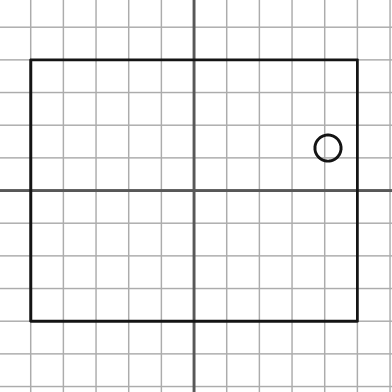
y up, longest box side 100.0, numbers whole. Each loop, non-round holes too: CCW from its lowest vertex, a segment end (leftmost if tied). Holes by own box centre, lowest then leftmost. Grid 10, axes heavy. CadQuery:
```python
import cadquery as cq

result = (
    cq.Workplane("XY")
    .moveTo(-50.0, -40.0)
    .lineTo(50.0, -40.0)
    .lineTo(50.0, 40.0)
    .lineTo(-50.0, 40.0)
    .close()
    .moveTo(41.0, 13.0)
    .circle(4.0)
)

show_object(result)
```